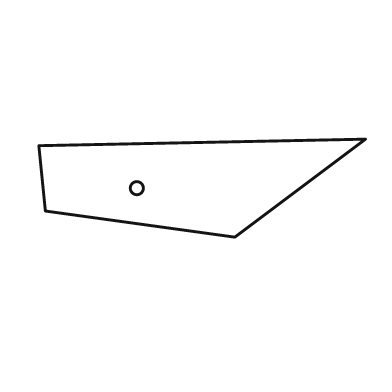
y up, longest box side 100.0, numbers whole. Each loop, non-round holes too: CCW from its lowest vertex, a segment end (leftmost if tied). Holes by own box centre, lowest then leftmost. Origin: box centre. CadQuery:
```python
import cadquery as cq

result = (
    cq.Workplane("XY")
    .moveTo(10.0, -15.0)
    .lineTo(50.0, 15.0)
    .lineTo(-50.0, 13.0)
    .lineTo(-48.0, -7.0)
    .close()
    .moveTo(-20.0, 0.0)
    .circle(2.0)
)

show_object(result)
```